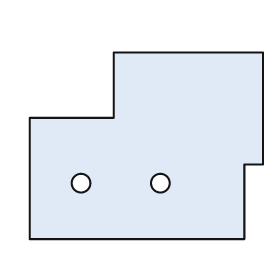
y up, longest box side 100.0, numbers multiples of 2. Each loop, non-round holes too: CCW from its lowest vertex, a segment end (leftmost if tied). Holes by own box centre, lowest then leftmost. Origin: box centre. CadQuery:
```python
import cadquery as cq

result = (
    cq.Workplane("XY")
    .moveTo(-50.0, -40.0)
    .lineTo(42.0, -40.0)
    .lineTo(42.0, -8.0)
    .lineTo(50.0, -8.0)
    .lineTo(50.0, 40.0)
    .lineTo(-14.0, 40.0)
    .lineTo(-14.0, 12.0)
    .lineTo(-50.0, 12.0)
    .close()
    .moveTo(-28.0, -16.0)
    .circle(4.0)
    .moveTo(6.0, -16.0)
    .circle(4.0)
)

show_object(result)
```